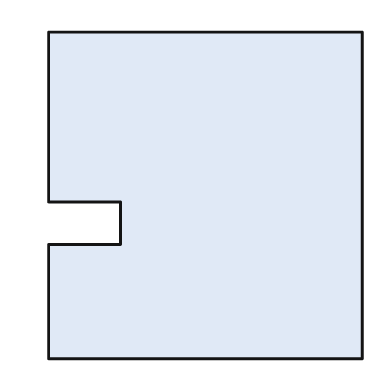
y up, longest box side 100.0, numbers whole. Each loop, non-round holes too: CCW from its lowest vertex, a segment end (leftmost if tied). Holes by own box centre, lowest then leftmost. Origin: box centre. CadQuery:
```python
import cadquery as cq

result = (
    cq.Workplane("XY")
    .moveTo(-48.0, -50.0)
    .lineTo(48.0, -50.0)
    .lineTo(48.0, 50.0)
    .lineTo(-48.0, 50.0)
    .lineTo(-48.0, -2.0)
    .lineTo(-26.0, -2.0)
    .lineTo(-26.0, -15.0)
    .lineTo(-48.0, -15.0)
    .close()
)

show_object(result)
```